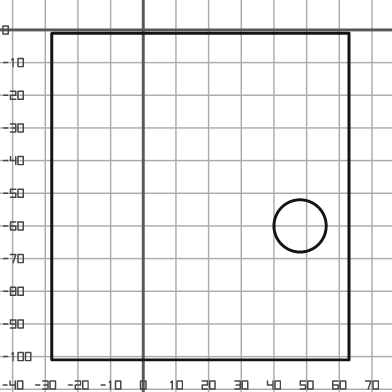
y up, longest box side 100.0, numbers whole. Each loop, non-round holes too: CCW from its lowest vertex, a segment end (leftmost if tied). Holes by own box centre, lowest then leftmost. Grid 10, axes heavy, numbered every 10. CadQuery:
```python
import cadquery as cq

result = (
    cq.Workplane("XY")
    .moveTo(-28.0, -101.0)
    .lineTo(63.0, -101.0)
    .lineTo(63.0, -1.0)
    .lineTo(-28.0, -1.0)
    .close()
    .moveTo(48.0, -60.0)
    .circle(8.0)
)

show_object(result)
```